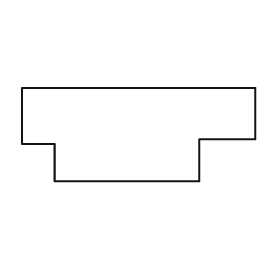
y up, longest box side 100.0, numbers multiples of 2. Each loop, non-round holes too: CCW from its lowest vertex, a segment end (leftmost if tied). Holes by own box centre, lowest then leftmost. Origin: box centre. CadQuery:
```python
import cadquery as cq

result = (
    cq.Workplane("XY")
    .moveTo(-36.0, -20.0)
    .lineTo(26.0, -20.0)
    .lineTo(26.0, -2.0)
    .lineTo(50.0, -2.0)
    .lineTo(50.0, 20.0)
    .lineTo(-50.0, 20.0)
    .lineTo(-50.0, -4.0)
    .lineTo(-36.0, -4.0)
    .close()
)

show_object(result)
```